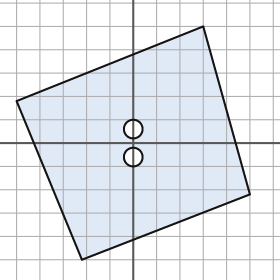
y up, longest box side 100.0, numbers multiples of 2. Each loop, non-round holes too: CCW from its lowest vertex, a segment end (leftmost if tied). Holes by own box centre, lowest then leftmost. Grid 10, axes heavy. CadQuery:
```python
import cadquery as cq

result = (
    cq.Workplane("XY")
    .moveTo(-22.0, -50.0)
    .lineTo(50.0, -22.0)
    .lineTo(30.0, 50.0)
    .lineTo(-50.0, 18.0)
    .close()
    .moveTo(0.0, -6.0)
    .circle(4.0)
    .moveTo(0.0, 6.0)
    .circle(4.0)
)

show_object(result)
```